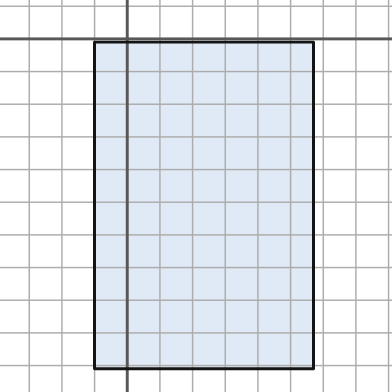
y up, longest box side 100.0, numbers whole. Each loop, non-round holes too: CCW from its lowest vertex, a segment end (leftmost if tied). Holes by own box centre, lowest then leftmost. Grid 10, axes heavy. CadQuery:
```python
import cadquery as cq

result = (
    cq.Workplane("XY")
    .moveTo(-10.0, -101.0)
    .lineTo(57.0, -101.0)
    .lineTo(57.0, -1.0)
    .lineTo(-10.0, -1.0)
    .close()
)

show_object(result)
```